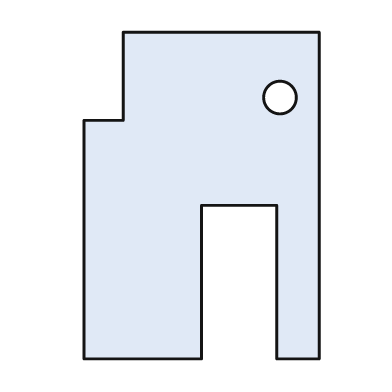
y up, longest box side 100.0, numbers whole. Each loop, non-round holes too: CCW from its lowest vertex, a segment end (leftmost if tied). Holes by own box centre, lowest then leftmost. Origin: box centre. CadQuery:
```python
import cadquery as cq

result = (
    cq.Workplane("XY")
    .moveTo(-36.0, -50.0)
    .lineTo(0.0, -50.0)
    .lineTo(0.0, -3.0)
    .lineTo(23.0, -3.0)
    .lineTo(23.0, -50.0)
    .lineTo(36.0, -50.0)
    .lineTo(36.0, 50.0)
    .lineTo(-24.0, 50.0)
    .lineTo(-24.0, 23.0)
    .lineTo(-36.0, 23.0)
    .close()
    .moveTo(24.0, 30.0)
    .circle(5.0)
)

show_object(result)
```